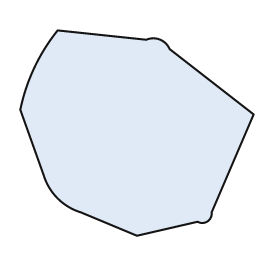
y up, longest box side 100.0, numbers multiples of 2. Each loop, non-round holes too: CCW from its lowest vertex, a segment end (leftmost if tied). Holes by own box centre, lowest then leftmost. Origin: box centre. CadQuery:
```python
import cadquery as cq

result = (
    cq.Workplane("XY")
    .moveTo(0.0, -44.0)
    .lineTo(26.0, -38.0)
    .threePointArc((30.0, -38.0), (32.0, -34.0))
    .lineTo(50.0, 8.0)
    .lineTo(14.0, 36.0)
    .threePointArc((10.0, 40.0), (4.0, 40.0))
    .lineTo(-34.0, 44.0)
    .threePointArc((-44.0, 28.0), (-50.0, 10.0))
    .lineTo(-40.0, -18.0)
    .threePointArc((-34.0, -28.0), (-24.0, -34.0))
    .close()
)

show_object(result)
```